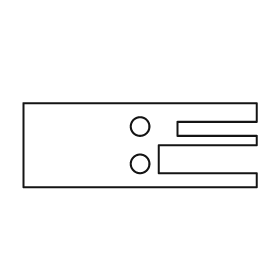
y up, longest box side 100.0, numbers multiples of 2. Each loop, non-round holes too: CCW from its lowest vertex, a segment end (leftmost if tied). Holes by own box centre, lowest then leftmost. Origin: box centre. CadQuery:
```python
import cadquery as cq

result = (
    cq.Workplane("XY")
    .moveTo(-50.0, -18.0)
    .lineTo(50.0, -18.0)
    .lineTo(50.0, -12.0)
    .lineTo(8.0, -12.0)
    .lineTo(8.0, 0.0)
    .lineTo(50.0, 0.0)
    .lineTo(50.0, 4.0)
    .lineTo(16.0, 4.0)
    .lineTo(16.0, 10.0)
    .lineTo(50.0, 10.0)
    .lineTo(50.0, 18.0)
    .lineTo(-50.0, 18.0)
    .close()
    .moveTo(0.0, -8.0)
    .circle(4.0)
    .moveTo(0.0, 8.0)
    .circle(4.0)
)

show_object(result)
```